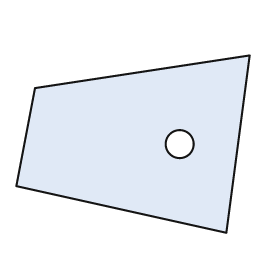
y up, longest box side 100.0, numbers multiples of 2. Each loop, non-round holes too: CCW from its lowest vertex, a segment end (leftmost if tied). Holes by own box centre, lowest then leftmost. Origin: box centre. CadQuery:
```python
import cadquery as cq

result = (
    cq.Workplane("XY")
    .moveTo(40.0, -38.0)
    .lineTo(50.0, 38.0)
    .lineTo(-42.0, 24.0)
    .lineTo(-50.0, -18.0)
    .close()
    .moveTo(20.0, 0.0)
    .circle(6.0)
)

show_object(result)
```